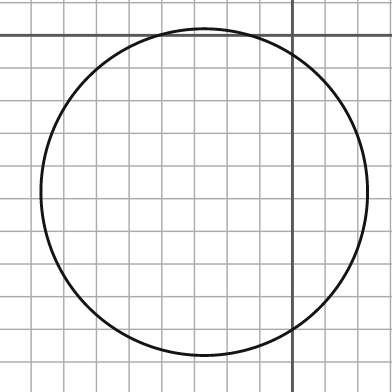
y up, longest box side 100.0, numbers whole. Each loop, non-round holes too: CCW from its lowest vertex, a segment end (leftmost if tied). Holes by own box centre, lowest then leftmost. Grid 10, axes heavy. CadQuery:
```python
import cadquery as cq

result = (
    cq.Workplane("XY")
    .moveTo(-27.0, -48.0)
    .circle(50.0)
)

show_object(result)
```